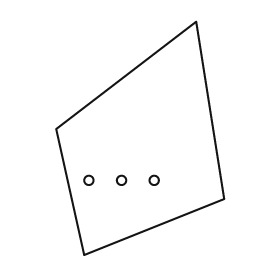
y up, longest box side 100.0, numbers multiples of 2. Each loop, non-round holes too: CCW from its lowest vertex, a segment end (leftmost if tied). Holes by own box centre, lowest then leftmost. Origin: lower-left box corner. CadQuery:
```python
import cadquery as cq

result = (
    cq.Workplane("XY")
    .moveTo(12.0, 0.0)
    .lineTo(72.0, 24.0)
    .lineTo(60.0, 100.0)
    .lineTo(0.0, 54.0)
    .close()
    .moveTo(14.0, 32.0)
    .circle(2.0)
    .moveTo(28.0, 32.0)
    .circle(2.0)
    .moveTo(42.0, 32.0)
    .circle(2.0)
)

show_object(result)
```